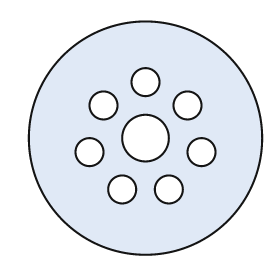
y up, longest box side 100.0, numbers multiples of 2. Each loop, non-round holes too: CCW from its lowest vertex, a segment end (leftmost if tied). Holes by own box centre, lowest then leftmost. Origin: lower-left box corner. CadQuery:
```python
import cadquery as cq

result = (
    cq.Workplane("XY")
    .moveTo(50.0, 50.0)
    .circle(50.0)
    .moveTo(40.0, 28.0)
    .circle(6.0)
    .moveTo(60.0, 28.0)
    .circle(6.0)
    .moveTo(26.0, 44.0)
    .circle(6.0)
    .moveTo(74.0, 44.0)
    .circle(6.0)
    .moveTo(50.0, 50.0)
    .circle(10.0)
    .moveTo(32.0, 64.0)
    .circle(6.0)
    .moveTo(68.0, 64.0)
    .circle(6.0)
    .moveTo(50.0, 74.0)
    .circle(6.0)
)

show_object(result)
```